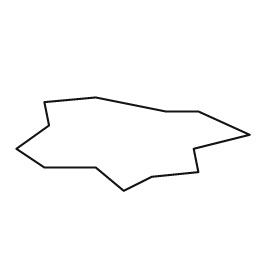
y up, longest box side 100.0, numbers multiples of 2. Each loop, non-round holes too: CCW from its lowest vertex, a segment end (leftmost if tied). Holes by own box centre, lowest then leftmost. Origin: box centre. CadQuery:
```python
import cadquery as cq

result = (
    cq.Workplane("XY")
    .moveTo(-4.0, -20.0)
    .lineTo(8.0, -14.0)
    .lineTo(28.0, -12.0)
    .lineTo(26.0, -2.0)
    .lineTo(50.0, 4.0)
    .lineTo(28.0, 14.0)
    .lineTo(14.0, 14.0)
    .lineTo(-16.0, 20.0)
    .lineTo(-38.0, 18.0)
    .lineTo(-36.0, 8.0)
    .lineTo(-50.0, -2.0)
    .lineTo(-38.0, -10.0)
    .lineTo(-16.0, -10.0)
    .close()
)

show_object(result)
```